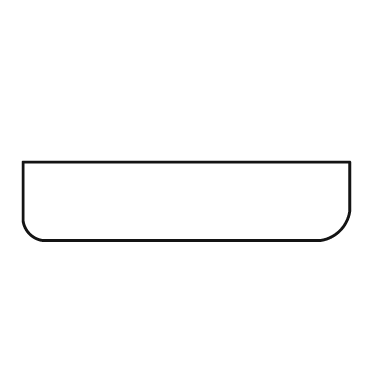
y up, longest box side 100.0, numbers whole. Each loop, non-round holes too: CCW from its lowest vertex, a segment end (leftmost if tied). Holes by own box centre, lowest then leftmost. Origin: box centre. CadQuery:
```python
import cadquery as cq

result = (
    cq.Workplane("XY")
    .moveTo(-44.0, -12.0)
    .lineTo(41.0, -12.0)
    .threePointArc((47.0, -9.0), (50.0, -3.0))
    .lineTo(50.0, 12.0)
    .lineTo(-50.0, 12.0)
    .lineTo(-50.0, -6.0)
    .threePointArc((-48.0, -10.0), (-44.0, -12.0))
    .close()
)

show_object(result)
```